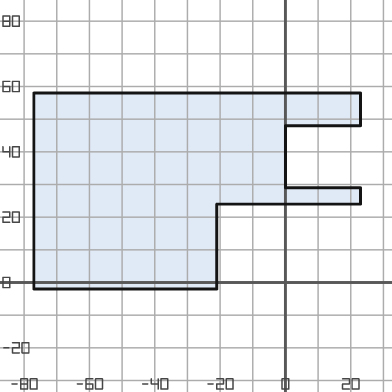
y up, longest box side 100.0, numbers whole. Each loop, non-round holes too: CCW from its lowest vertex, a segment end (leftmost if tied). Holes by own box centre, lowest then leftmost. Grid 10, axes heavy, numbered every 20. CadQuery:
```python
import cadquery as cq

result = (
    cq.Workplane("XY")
    .moveTo(-77.0, -2.0)
    .lineTo(-21.0, -2.0)
    .lineTo(-21.0, 24.0)
    .lineTo(23.0, 24.0)
    .lineTo(23.0, 29.0)
    .lineTo(0.0, 29.0)
    .lineTo(0.0, 48.0)
    .lineTo(23.0, 48.0)
    .lineTo(23.0, 58.0)
    .lineTo(-77.0, 58.0)
    .close()
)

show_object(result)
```